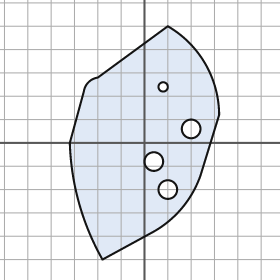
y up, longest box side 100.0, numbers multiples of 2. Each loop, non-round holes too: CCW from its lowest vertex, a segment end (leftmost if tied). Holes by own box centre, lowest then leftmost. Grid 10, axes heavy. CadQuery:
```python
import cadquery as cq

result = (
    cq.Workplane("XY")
    .moveTo(-18.0, -50.0)
    .lineTo(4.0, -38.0)
    .threePointArc((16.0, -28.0), (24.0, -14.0))
    .lineTo(32.0, 12.0)
    .threePointArc((26.0, 34.0), (10.0, 50.0))
    .lineTo(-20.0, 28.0)
    .threePointArc((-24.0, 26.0), (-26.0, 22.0))
    .lineTo(-32.0, 0.0)
    .threePointArc((-28.0, -26.0), (-18.0, -50.0))
    .close()
    .moveTo(10.0, -20.0)
    .circle(4.0)
    .moveTo(4.0, -8.0)
    .circle(4.0)
    .moveTo(20.0, 6.0)
    .circle(4.0)
    .moveTo(8.0, 24.0)
    .circle(2.0)
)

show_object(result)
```